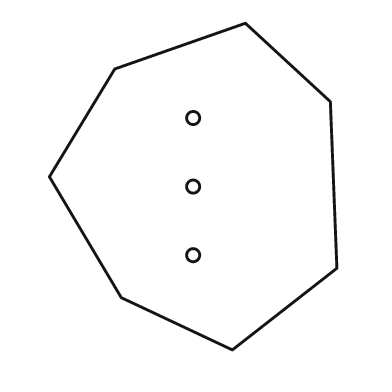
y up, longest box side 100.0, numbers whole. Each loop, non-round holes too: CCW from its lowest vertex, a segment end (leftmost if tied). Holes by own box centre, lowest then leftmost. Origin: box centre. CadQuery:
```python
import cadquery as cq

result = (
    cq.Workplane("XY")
    .moveTo(12.0, -50.0)
    .lineTo(44.0, -25.0)
    .lineTo(42.0, 26.0)
    .lineTo(16.0, 50.0)
    .lineTo(-24.0, 36.0)
    .lineTo(-44.0, 3.0)
    .lineTo(-22.0, -34.0)
    .close()
    .moveTo(0.0, -21.0)
    .circle(2.0)
    .moveTo(0.0, 0.0)
    .circle(2.0)
    .moveTo(0.0, 21.0)
    .circle(2.0)
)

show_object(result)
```